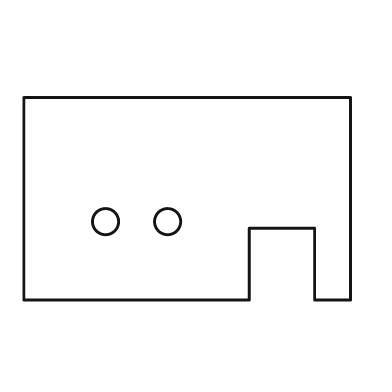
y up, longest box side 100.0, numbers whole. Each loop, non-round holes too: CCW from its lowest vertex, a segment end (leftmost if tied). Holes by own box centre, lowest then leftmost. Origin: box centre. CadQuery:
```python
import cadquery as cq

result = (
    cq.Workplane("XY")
    .moveTo(-50.0, -31.0)
    .lineTo(19.0, -31.0)
    .lineTo(19.0, -9.0)
    .lineTo(39.0, -9.0)
    .lineTo(39.0, -31.0)
    .lineTo(50.0, -31.0)
    .lineTo(50.0, 31.0)
    .lineTo(-50.0, 31.0)
    .close()
    .moveTo(-25.0, -7.0)
    .circle(4.0)
    .moveTo(-6.0, -7.0)
    .circle(4.0)
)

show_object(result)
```